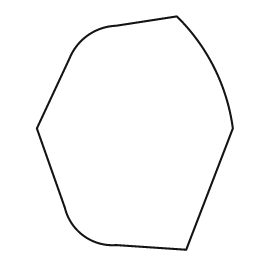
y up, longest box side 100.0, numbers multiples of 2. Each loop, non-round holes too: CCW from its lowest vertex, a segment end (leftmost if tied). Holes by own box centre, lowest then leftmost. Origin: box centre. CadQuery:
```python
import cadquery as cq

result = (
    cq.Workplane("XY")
    .moveTo(22.0, -50.0)
    .lineTo(42.0, 2.0)
    .threePointArc((34.0, 28.0), (18.0, 50.0))
    .lineTo(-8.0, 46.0)
    .threePointArc((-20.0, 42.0), (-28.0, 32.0))
    .lineTo(-42.0, 2.0)
    .lineTo(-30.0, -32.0)
    .threePointArc((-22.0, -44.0), (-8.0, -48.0))
    .close()
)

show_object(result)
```